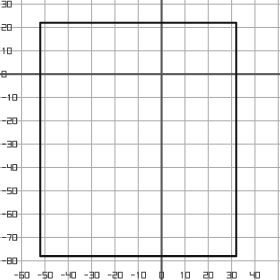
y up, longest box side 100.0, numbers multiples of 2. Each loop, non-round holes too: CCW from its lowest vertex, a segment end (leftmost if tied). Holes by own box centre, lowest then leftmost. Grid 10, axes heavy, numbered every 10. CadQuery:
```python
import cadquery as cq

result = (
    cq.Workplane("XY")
    .moveTo(-52.0, -78.0)
    .lineTo(32.0, -78.0)
    .lineTo(32.0, 22.0)
    .lineTo(-52.0, 22.0)
    .close()
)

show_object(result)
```